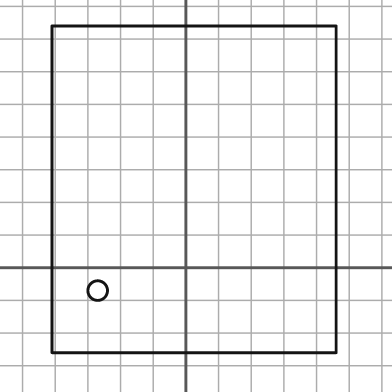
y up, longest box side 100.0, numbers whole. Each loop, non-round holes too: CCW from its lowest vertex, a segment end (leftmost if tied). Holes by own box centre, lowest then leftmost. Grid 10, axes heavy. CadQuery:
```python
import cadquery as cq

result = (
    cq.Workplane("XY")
    .moveTo(-41.0, -26.0)
    .lineTo(46.0, -26.0)
    .lineTo(46.0, 74.0)
    .lineTo(-41.0, 74.0)
    .close()
    .moveTo(-27.0, -7.0)
    .circle(3.0)
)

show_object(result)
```